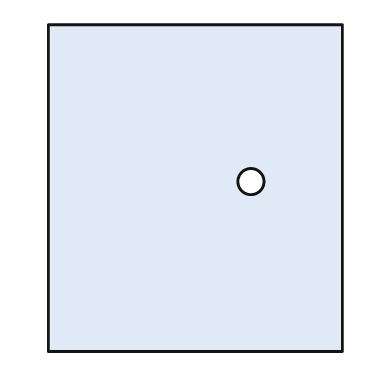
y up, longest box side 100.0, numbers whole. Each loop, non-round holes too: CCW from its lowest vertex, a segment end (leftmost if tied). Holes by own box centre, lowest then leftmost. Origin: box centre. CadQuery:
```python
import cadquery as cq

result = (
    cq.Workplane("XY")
    .moveTo(-45.0, -50.0)
    .lineTo(45.0, -50.0)
    .lineTo(45.0, 50.0)
    .lineTo(-45.0, 50.0)
    .close()
    .moveTo(17.0, 2.0)
    .circle(4.0)
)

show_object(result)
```